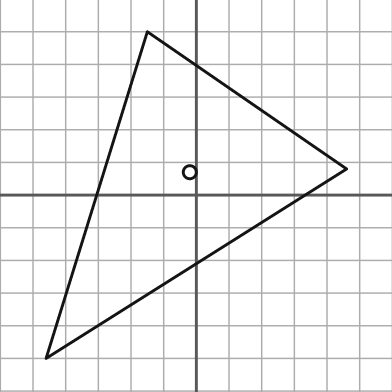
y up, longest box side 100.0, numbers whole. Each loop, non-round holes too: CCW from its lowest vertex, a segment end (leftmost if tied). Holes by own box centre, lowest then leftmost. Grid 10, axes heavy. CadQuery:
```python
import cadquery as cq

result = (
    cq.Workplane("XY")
    .moveTo(-46.0, -50.0)
    .lineTo(46.0, 8.0)
    .lineTo(-15.0, 50.0)
    .close()
    .moveTo(-2.0, 7.0)
    .circle(2.0)
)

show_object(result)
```